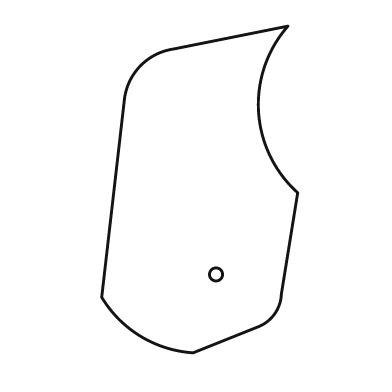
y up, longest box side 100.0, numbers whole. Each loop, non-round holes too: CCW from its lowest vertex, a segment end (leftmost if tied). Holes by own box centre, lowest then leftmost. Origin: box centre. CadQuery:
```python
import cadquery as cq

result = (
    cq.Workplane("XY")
    .moveTo(-2.0, -50.0)
    .lineTo(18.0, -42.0)
    .threePointArc((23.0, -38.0), (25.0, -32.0))
    .lineTo(30.0, -1.0)
    .threePointArc((18.0, 24.0), (27.0, 50.0))
    .lineTo(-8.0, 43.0)
    .threePointArc((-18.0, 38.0), (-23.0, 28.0))
    .lineTo(-30.0, -33.0)
    .threePointArc((-18.0, -45.0), (-2.0, -50.0))
    .close()
    .moveTo(5.0, -26.0)
    .circle(2.0)
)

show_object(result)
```